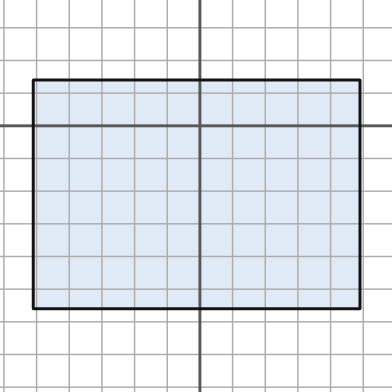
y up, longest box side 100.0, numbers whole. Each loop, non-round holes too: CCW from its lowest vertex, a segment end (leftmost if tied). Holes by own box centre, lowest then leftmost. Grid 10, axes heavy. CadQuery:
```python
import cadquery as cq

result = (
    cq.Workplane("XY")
    .moveTo(-51.0, -56.0)
    .lineTo(49.0, -56.0)
    .lineTo(49.0, 14.0)
    .lineTo(-51.0, 14.0)
    .close()
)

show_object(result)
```